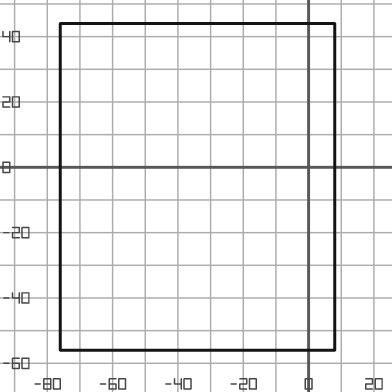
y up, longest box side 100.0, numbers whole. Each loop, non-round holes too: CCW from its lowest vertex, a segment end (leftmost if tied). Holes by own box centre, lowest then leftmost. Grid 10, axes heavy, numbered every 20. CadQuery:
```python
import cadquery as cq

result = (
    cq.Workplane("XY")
    .moveTo(-76.0, -56.0)
    .lineTo(8.0, -56.0)
    .lineTo(8.0, 44.0)
    .lineTo(-76.0, 44.0)
    .close()
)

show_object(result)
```